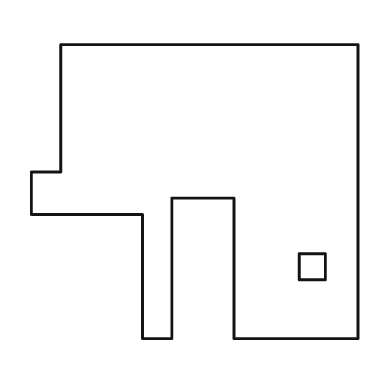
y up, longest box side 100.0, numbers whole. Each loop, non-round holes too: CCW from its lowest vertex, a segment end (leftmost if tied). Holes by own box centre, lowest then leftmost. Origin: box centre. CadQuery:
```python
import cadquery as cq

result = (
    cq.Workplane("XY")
    .moveTo(-16.0, -45.0)
    .lineTo(-7.0, -45.0)
    .lineTo(-7.0, -2.0)
    .lineTo(12.0, -2.0)
    .lineTo(12.0, -45.0)
    .lineTo(50.0, -45.0)
    .lineTo(50.0, 45.0)
    .lineTo(-41.0, 45.0)
    .lineTo(-41.0, 6.0)
    .lineTo(-50.0, 6.0)
    .lineTo(-50.0, -7.0)
    .lineTo(-16.0, -7.0)
    .close()
    .moveTo(32.0, -27.0)
    .lineTo(40.0, -27.0)
    .lineTo(40.0, -19.0)
    .lineTo(32.0, -19.0)
    .close()
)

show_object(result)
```